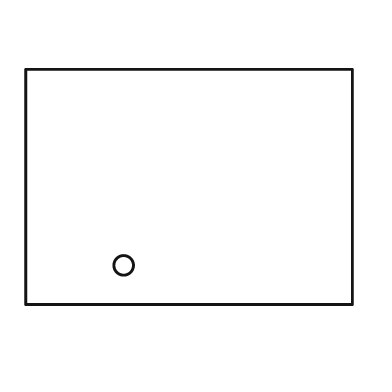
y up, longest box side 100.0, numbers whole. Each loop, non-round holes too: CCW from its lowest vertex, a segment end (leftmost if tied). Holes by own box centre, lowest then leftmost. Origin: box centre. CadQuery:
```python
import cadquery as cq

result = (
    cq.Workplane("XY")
    .moveTo(-50.0, -36.0)
    .lineTo(50.0, -36.0)
    .lineTo(50.0, 36.0)
    .lineTo(-50.0, 36.0)
    .close()
    .moveTo(-20.0, -24.0)
    .circle(3.0)
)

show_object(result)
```